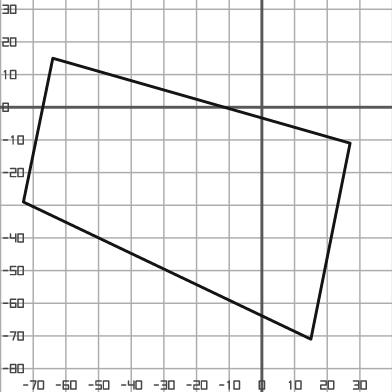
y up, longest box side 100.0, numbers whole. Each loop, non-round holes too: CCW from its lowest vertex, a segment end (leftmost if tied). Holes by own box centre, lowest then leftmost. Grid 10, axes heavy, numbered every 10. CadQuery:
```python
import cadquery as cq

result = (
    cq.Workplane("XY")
    .moveTo(15.0, -71.0)
    .lineTo(27.0, -11.0)
    .lineTo(-64.0, 15.0)
    .lineTo(-73.0, -29.0)
    .close()
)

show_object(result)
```